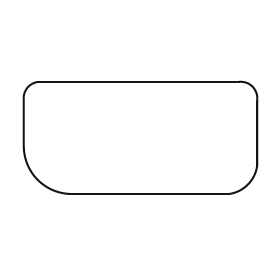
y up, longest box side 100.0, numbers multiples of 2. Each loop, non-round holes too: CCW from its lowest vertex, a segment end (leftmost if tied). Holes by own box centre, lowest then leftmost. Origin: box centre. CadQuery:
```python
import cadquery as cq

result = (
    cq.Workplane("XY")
    .moveTo(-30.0, -24.0)
    .lineTo(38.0, -24.0)
    .threePointArc((46.0, -20.0), (50.0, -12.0))
    .lineTo(50.0, 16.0)
    .threePointArc((48.0, 22.0), (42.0, 24.0))
    .lineTo(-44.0, 24.0)
    .threePointArc((-48.0, 22.0), (-50.0, 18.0))
    .lineTo(-50.0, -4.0)
    .threePointArc((-44.0, -18.0), (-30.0, -24.0))
    .close()
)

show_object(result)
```